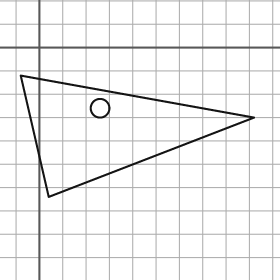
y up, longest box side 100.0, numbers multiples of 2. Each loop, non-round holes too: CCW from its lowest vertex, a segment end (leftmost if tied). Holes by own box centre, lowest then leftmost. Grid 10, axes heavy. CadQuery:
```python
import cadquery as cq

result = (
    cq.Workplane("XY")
    .moveTo(4.0, -64.0)
    .lineTo(92.0, -30.0)
    .lineTo(-8.0, -12.0)
    .close()
    .moveTo(26.0, -26.0)
    .circle(4.0)
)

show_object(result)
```